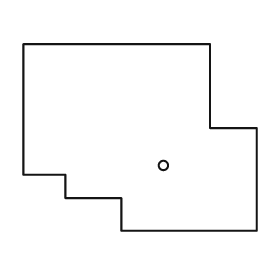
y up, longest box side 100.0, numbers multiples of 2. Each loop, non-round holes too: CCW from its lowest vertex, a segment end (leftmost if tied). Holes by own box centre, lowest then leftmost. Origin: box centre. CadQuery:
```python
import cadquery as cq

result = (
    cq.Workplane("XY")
    .moveTo(-8.0, -40.0)
    .lineTo(50.0, -40.0)
    .lineTo(50.0, 4.0)
    .lineTo(30.0, 4.0)
    .lineTo(30.0, 40.0)
    .lineTo(-50.0, 40.0)
    .lineTo(-50.0, -16.0)
    .lineTo(-32.0, -16.0)
    .lineTo(-32.0, -26.0)
    .lineTo(-8.0, -26.0)
    .close()
    .moveTo(10.0, -12.0)
    .circle(2.0)
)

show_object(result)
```